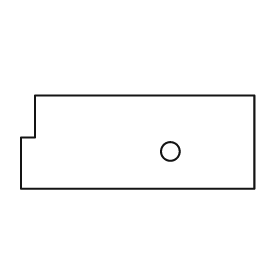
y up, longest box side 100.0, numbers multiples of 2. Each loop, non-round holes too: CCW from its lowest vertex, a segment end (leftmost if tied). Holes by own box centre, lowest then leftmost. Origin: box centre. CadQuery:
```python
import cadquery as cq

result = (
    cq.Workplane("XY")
    .moveTo(-50.0, -20.0)
    .lineTo(50.0, -20.0)
    .lineTo(50.0, 20.0)
    .lineTo(-44.0, 20.0)
    .lineTo(-44.0, 2.0)
    .lineTo(-50.0, 2.0)
    .close()
    .moveTo(14.0, -4.0)
    .circle(4.0)
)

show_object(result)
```